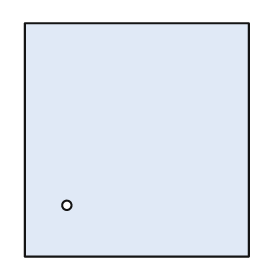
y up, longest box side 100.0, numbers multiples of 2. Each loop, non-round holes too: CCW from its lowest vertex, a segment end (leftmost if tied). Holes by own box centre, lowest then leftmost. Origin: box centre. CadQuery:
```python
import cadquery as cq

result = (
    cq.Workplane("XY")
    .moveTo(-48.0, -50.0)
    .lineTo(48.0, -50.0)
    .lineTo(48.0, 50.0)
    .lineTo(-48.0, 50.0)
    .close()
    .moveTo(-30.0, -28.0)
    .circle(2.0)
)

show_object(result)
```